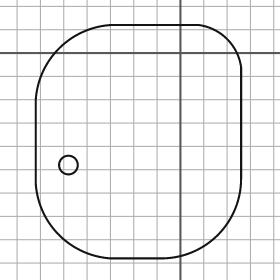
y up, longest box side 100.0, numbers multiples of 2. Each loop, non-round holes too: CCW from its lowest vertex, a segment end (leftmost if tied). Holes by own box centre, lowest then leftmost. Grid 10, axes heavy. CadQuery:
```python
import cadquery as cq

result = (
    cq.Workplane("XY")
    .moveTo(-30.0, -88.0)
    .lineTo(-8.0, -88.0)
    .threePointArc((16.0, -78.0), (26.0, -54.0))
    .lineTo(26.0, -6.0)
    .threePointArc((20.0, 6.0), (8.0, 12.0))
    .lineTo(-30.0, 12.0)
    .threePointArc((-52.0, 2.0), (-62.0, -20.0))
    .lineTo(-62.0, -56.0)
    .threePointArc((-52.0, -78.0), (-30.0, -88.0))
    .close()
    .moveTo(-48.0, -48.0)
    .circle(4.0)
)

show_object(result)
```